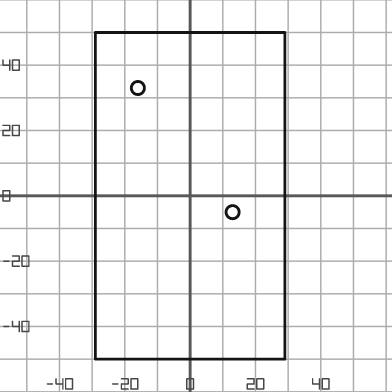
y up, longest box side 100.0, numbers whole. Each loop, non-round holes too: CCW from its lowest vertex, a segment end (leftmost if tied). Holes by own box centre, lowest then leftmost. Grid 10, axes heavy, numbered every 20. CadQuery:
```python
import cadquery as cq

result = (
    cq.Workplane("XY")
    .moveTo(-29.0, -50.0)
    .lineTo(29.0, -50.0)
    .lineTo(29.0, 50.0)
    .lineTo(-29.0, 50.0)
    .close()
    .moveTo(13.0, -5.0)
    .circle(2.0)
    .moveTo(-16.0, 33.0)
    .circle(2.0)
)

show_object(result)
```